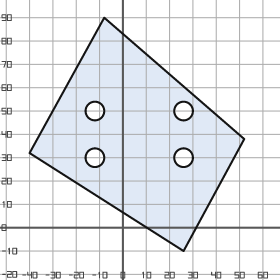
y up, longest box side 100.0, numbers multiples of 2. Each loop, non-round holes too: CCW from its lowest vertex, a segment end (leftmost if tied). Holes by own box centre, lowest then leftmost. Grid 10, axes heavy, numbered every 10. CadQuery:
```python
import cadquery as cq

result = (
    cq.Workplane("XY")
    .moveTo(26.0, -10.0)
    .lineTo(52.0, 38.0)
    .lineTo(-8.0, 90.0)
    .lineTo(-40.0, 32.0)
    .close()
    .moveTo(-12.0, 30.0)
    .circle(4.0)
    .moveTo(26.0, 30.0)
    .circle(4.0)
    .moveTo(-12.0, 50.0)
    .circle(4.0)
    .moveTo(26.0, 50.0)
    .circle(4.0)
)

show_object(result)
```